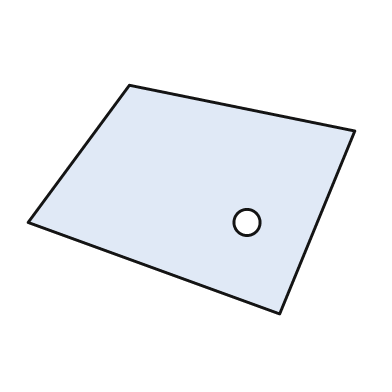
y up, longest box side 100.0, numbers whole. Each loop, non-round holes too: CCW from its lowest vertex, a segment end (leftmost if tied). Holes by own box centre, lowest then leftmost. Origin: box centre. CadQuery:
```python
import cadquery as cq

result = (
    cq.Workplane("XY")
    .moveTo(27.0, -35.0)
    .lineTo(50.0, 21.0)
    .lineTo(-19.0, 35.0)
    .lineTo(-50.0, -7.0)
    .close()
    .moveTo(17.0, -7.0)
    .circle(4.0)
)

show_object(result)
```